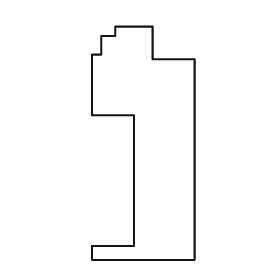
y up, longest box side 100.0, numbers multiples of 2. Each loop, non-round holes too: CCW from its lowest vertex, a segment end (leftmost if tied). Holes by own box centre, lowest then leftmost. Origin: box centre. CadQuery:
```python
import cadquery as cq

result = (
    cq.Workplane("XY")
    .moveTo(-22.0, -50.0)
    .lineTo(22.0, -50.0)
    .lineTo(22.0, 36.0)
    .lineTo(4.0, 36.0)
    .lineTo(4.0, 50.0)
    .lineTo(-12.0, 50.0)
    .lineTo(-12.0, 46.0)
    .lineTo(-18.0, 46.0)
    .lineTo(-18.0, 38.0)
    .lineTo(-22.0, 38.0)
    .lineTo(-22.0, 12.0)
    .lineTo(-4.0, 12.0)
    .lineTo(-4.0, -44.0)
    .lineTo(-22.0, -44.0)
    .close()
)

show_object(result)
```